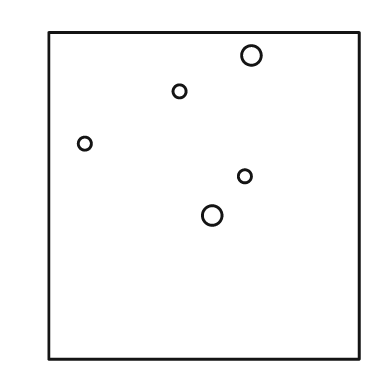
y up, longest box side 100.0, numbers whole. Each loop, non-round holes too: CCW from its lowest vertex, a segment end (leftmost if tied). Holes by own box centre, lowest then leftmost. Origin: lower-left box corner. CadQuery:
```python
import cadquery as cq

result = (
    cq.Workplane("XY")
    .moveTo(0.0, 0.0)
    .lineTo(95.0, 0.0)
    .lineTo(95.0, 100.0)
    .lineTo(0.0, 100.0)
    .close()
    .moveTo(50.0, 44.0)
    .circle(3.0)
    .moveTo(60.0, 56.0)
    .circle(2.0)
    .moveTo(11.0, 66.0)
    .circle(2.0)
    .moveTo(40.0, 82.0)
    .circle(2.0)
    .moveTo(62.0, 93.0)
    .circle(3.0)
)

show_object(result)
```